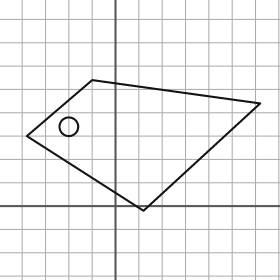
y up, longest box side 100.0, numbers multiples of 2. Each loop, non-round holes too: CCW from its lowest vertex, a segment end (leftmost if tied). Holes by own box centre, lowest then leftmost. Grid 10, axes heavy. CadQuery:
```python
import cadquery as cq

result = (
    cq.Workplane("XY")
    .moveTo(12.0, -2.0)
    .lineTo(62.0, 44.0)
    .lineTo(-10.0, 54.0)
    .lineTo(-38.0, 30.0)
    .close()
    .moveTo(-20.0, 34.0)
    .circle(4.0)
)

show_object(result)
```